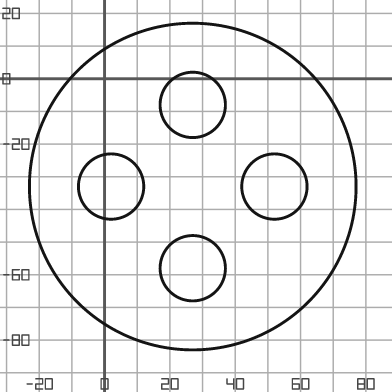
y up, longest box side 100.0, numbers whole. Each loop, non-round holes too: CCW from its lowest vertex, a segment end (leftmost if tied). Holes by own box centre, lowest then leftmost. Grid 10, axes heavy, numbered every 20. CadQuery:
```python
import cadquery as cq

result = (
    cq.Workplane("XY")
    .moveTo(27.0, -33.0)
    .circle(50.0)
    .moveTo(27.0, -58.0)
    .circle(10.0)
    .moveTo(2.0, -33.0)
    .circle(10.0)
    .moveTo(52.0, -33.0)
    .circle(10.0)
    .moveTo(27.0, -8.0)
    .circle(10.0)
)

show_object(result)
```